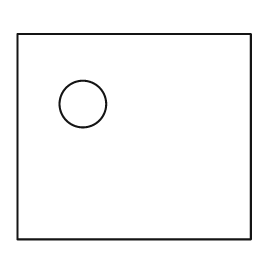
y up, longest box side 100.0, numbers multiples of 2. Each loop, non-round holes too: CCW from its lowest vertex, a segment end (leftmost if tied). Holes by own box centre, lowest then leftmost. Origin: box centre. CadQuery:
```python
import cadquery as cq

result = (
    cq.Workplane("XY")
    .moveTo(-50.0, -44.0)
    .lineTo(50.0, -44.0)
    .lineTo(50.0, 44.0)
    .lineTo(-50.0, 44.0)
    .close()
    .moveTo(-22.0, 14.0)
    .circle(10.0)
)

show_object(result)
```